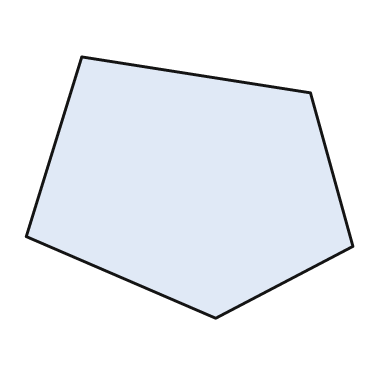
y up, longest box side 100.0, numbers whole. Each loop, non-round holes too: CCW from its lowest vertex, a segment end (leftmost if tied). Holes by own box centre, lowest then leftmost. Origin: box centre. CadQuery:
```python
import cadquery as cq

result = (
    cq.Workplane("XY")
    .moveTo(8.0, -40.0)
    .lineTo(50.0, -18.0)
    .lineTo(37.0, 29.0)
    .lineTo(-33.0, 40.0)
    .lineTo(-50.0, -15.0)
    .close()
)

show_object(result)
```